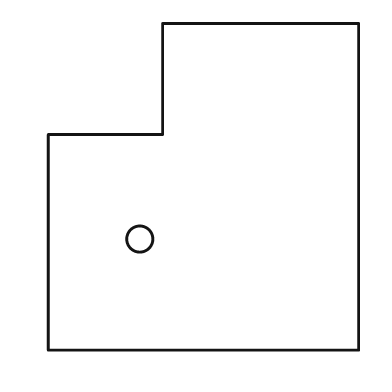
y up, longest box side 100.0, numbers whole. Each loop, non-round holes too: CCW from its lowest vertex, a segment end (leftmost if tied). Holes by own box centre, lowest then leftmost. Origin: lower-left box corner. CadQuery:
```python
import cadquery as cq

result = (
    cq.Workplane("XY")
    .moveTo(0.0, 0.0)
    .lineTo(95.0, 0.0)
    .lineTo(95.0, 100.0)
    .lineTo(35.0, 100.0)
    .lineTo(35.0, 66.0)
    .lineTo(0.0, 66.0)
    .close()
    .moveTo(28.0, 34.0)
    .circle(4.0)
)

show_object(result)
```